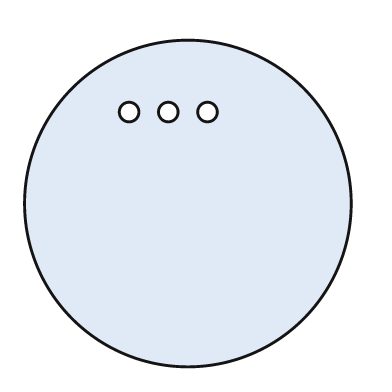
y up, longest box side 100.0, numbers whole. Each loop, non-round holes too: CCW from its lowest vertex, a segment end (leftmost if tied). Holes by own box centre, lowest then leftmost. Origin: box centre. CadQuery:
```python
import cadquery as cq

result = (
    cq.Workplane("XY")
    .moveTo(0.0, 0.0)
    .circle(50.0)
    .moveTo(-18.0, 28.0)
    .circle(3.0)
    .moveTo(-6.0, 28.0)
    .circle(3.0)
    .moveTo(6.0, 28.0)
    .circle(3.0)
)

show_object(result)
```